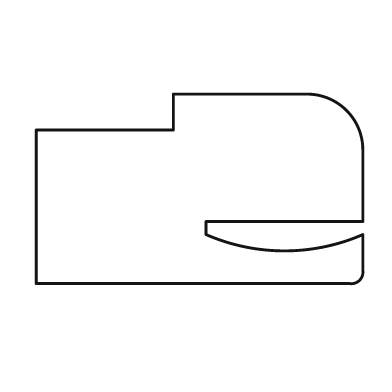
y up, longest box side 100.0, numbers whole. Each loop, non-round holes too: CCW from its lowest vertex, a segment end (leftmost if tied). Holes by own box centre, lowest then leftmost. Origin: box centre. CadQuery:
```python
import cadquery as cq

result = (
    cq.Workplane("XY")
    .moveTo(-50.0, -29.0)
    .lineTo(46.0, -29.0)
    .threePointArc((49.0, -28.0), (50.0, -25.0))
    .lineTo(50.0, -14.0)
    .threePointArc((26.0, -19.0), (2.0, -14.0))
    .lineTo(2.0, -10.0)
    .lineTo(50.0, -10.0)
    .lineTo(50.0, 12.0)
    .threePointArc((45.0, 24.0), (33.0, 29.0))
    .lineTo(-8.0, 29.0)
    .lineTo(-8.0, 18.0)
    .lineTo(-50.0, 18.0)
    .close()
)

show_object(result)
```